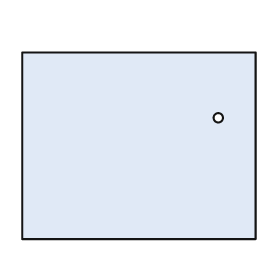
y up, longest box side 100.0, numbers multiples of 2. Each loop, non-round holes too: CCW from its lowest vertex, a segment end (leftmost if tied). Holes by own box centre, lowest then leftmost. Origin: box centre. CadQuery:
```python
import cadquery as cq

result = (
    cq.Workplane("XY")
    .moveTo(-50.0, -40.0)
    .lineTo(50.0, -40.0)
    .lineTo(50.0, 40.0)
    .lineTo(-50.0, 40.0)
    .close()
    .moveTo(34.0, 12.0)
    .circle(2.0)
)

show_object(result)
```